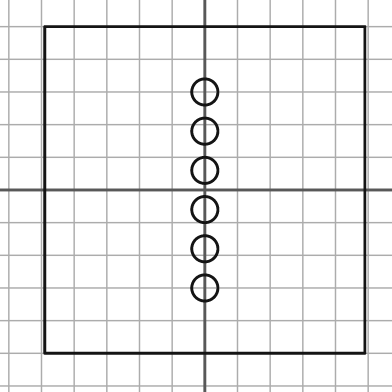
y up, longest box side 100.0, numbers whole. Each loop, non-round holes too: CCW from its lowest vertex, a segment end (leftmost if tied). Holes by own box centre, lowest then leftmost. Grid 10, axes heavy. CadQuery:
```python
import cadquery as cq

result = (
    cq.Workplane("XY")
    .moveTo(-49.0, -50.0)
    .lineTo(49.0, -50.0)
    .lineTo(49.0, 50.0)
    .lineTo(-49.0, 50.0)
    .close()
    .moveTo(0.0, -30.0)
    .circle(4.0)
    .moveTo(0.0, -18.0)
    .circle(4.0)
    .moveTo(0.0, -6.0)
    .circle(4.0)
    .moveTo(0.0, 6.0)
    .circle(4.0)
    .moveTo(0.0, 18.0)
    .circle(4.0)
    .moveTo(0.0, 30.0)
    .circle(4.0)
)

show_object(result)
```